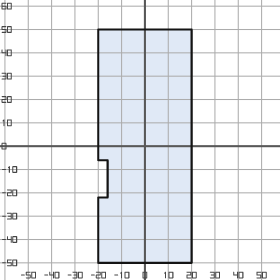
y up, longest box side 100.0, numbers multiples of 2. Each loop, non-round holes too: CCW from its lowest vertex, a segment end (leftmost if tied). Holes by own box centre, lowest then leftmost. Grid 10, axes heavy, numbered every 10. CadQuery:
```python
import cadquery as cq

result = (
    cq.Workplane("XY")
    .moveTo(-20.0, -50.0)
    .lineTo(20.0, -50.0)
    .lineTo(20.0, 50.0)
    .lineTo(-20.0, 50.0)
    .lineTo(-20.0, -6.0)
    .lineTo(-16.0, -6.0)
    .lineTo(-16.0, -22.0)
    .lineTo(-20.0, -22.0)
    .close()
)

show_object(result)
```